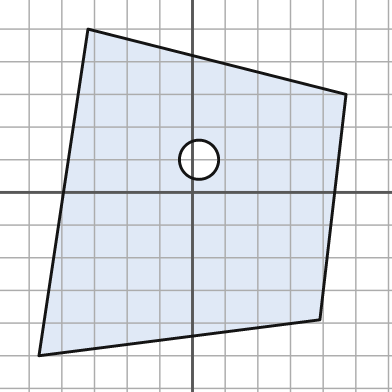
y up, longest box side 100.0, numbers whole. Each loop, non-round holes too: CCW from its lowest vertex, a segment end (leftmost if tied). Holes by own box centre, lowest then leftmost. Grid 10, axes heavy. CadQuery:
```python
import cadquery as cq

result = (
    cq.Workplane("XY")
    .moveTo(-47.0, -50.0)
    .lineTo(39.0, -39.0)
    .lineTo(47.0, 30.0)
    .lineTo(-32.0, 50.0)
    .close()
    .moveTo(2.0, 10.0)
    .circle(6.0)
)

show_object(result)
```